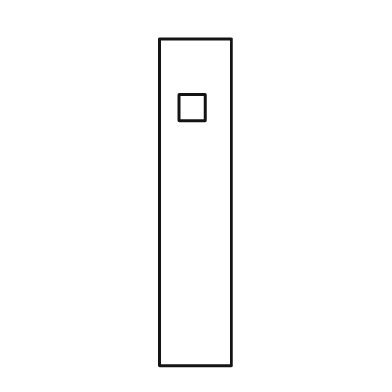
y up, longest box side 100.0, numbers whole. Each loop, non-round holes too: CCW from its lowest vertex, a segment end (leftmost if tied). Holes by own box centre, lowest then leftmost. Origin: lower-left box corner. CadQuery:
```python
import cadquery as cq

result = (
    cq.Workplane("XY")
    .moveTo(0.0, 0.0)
    .lineTo(22.0, 0.0)
    .lineTo(22.0, 100.0)
    .lineTo(0.0, 100.0)
    .close()
    .moveTo(6.0, 75.0)
    .lineTo(14.0, 75.0)
    .lineTo(14.0, 83.0)
    .lineTo(6.0, 83.0)
    .close()
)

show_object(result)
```